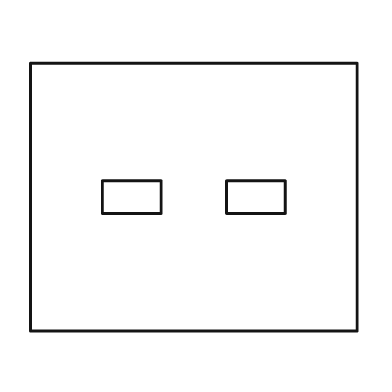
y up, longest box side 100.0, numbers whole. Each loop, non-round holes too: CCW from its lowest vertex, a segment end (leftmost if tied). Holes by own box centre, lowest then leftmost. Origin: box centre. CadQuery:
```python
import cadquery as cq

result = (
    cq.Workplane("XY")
    .moveTo(-50.0, -41.0)
    .lineTo(50.0, -41.0)
    .lineTo(50.0, 41.0)
    .lineTo(-50.0, 41.0)
    .close()
    .moveTo(-28.0, -5.0)
    .lineTo(-10.0, -5.0)
    .lineTo(-10.0, 5.0)
    .lineTo(-28.0, 5.0)
    .close()
    .moveTo(10.0, -5.0)
    .lineTo(28.0, -5.0)
    .lineTo(28.0, 5.0)
    .lineTo(10.0, 5.0)
    .close()
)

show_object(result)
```